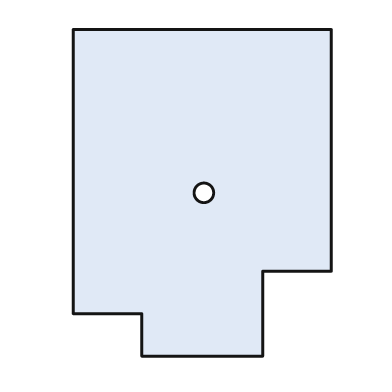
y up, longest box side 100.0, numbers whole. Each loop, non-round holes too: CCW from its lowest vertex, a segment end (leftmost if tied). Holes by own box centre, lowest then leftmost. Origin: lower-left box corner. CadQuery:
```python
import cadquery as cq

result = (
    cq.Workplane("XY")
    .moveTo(21.0, 0.0)
    .lineTo(58.0, 0.0)
    .lineTo(58.0, 26.0)
    .lineTo(79.0, 26.0)
    .lineTo(79.0, 100.0)
    .lineTo(0.0, 100.0)
    .lineTo(0.0, 13.0)
    .lineTo(21.0, 13.0)
    .close()
    .moveTo(40.0, 50.0)
    .circle(3.0)
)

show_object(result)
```